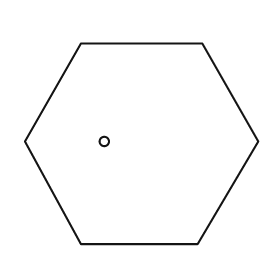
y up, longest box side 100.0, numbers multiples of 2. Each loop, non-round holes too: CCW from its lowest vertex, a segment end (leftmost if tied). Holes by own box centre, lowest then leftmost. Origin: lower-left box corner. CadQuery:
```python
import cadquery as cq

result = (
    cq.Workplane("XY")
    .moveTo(24.0, 0.0)
    .lineTo(74.0, 0.0)
    .lineTo(100.0, 44.0)
    .lineTo(76.0, 86.0)
    .lineTo(24.0, 86.0)
    .lineTo(0.0, 44.0)
    .close()
    .moveTo(34.0, 44.0)
    .circle(2.0)
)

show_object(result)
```